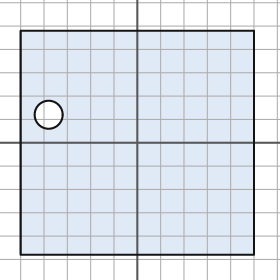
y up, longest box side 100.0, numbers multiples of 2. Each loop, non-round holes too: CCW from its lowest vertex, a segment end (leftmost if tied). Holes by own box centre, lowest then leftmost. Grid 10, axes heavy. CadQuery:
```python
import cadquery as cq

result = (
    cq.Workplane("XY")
    .moveTo(-50.0, -48.0)
    .lineTo(50.0, -48.0)
    .lineTo(50.0, 48.0)
    .lineTo(-50.0, 48.0)
    .close()
    .moveTo(-38.0, 12.0)
    .circle(6.0)
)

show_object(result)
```